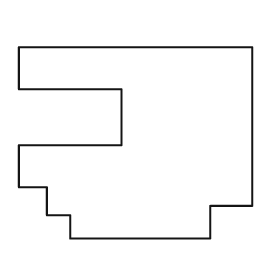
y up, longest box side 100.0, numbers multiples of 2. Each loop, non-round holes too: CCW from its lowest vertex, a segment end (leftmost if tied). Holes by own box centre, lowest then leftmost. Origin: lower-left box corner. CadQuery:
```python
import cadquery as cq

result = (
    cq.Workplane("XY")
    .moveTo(22.0, 0.0)
    .lineTo(82.0, 0.0)
    .lineTo(82.0, 14.0)
    .lineTo(100.0, 14.0)
    .lineTo(100.0, 82.0)
    .lineTo(0.0, 82.0)
    .lineTo(0.0, 64.0)
    .lineTo(44.0, 64.0)
    .lineTo(44.0, 40.0)
    .lineTo(0.0, 40.0)
    .lineTo(0.0, 22.0)
    .lineTo(12.0, 22.0)
    .lineTo(12.0, 10.0)
    .lineTo(22.0, 10.0)
    .close()
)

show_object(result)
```